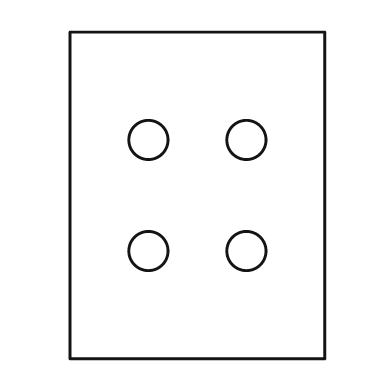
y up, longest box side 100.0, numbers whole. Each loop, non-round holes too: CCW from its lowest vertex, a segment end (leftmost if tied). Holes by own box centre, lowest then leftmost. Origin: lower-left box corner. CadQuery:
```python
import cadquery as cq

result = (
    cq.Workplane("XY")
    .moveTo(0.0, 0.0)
    .lineTo(78.0, 0.0)
    .lineTo(78.0, 100.0)
    .lineTo(0.0, 100.0)
    .close()
    .moveTo(24.0, 33.0)
    .circle(6.0)
    .moveTo(54.0, 33.0)
    .circle(6.0)
    .moveTo(24.0, 67.0)
    .circle(6.0)
    .moveTo(54.0, 67.0)
    .circle(6.0)
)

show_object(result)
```